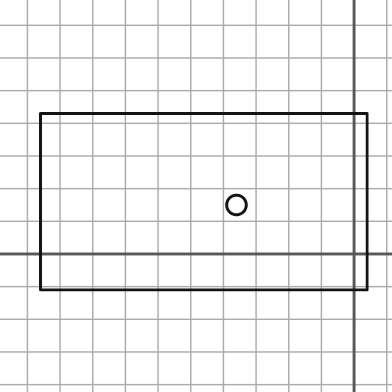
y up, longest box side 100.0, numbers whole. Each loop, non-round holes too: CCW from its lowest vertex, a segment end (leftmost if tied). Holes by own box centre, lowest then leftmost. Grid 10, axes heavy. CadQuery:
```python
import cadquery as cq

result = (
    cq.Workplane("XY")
    .moveTo(-96.0, -11.0)
    .lineTo(4.0, -11.0)
    .lineTo(4.0, 43.0)
    .lineTo(-96.0, 43.0)
    .close()
    .moveTo(-36.0, 15.0)
    .circle(3.0)
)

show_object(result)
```